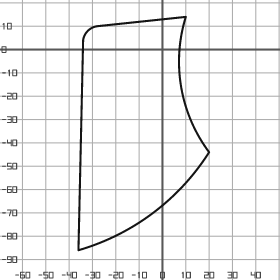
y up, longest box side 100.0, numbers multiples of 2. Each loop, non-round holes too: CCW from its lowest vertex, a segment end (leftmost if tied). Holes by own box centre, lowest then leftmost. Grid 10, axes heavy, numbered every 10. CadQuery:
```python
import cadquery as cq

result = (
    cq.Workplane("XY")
    .moveTo(-36.0, -86.0)
    .threePointArc((-4.0, -70.0), (20.0, -44.0))
    .threePointArc((8.0, -16.0), (10.0, 14.0))
    .lineTo(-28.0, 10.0)
    .threePointArc((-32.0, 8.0), (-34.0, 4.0))
    .close()
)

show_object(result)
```